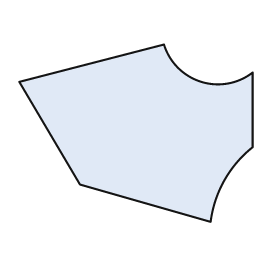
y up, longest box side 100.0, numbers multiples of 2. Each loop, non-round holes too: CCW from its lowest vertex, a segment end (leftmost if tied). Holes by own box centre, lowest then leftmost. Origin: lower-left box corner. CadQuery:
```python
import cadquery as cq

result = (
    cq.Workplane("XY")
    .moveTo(82.0, 0.0)
    .threePointArc((88.0, 18.0), (100.0, 32.0))
    .lineTo(100.0, 64.0)
    .threePointArc((78.0, 60.0), (62.0, 76.0))
    .lineTo(0.0, 60.0)
    .lineTo(26.0, 16.0)
    .close()
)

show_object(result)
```